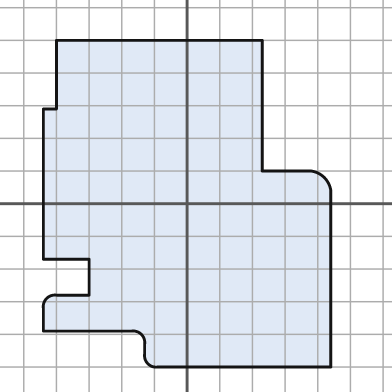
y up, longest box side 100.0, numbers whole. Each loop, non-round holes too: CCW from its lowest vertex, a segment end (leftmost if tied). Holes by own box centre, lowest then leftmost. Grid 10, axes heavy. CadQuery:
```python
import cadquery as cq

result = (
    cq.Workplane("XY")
    .moveTo(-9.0, -50.0)
    .lineTo(44.0, -50.0)
    .lineTo(44.0, 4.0)
    .threePointArc((42.0, 8.0), (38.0, 10.0))
    .lineTo(23.0, 10.0)
    .lineTo(23.0, 50.0)
    .lineTo(-40.0, 50.0)
    .lineTo(-40.0, 29.0)
    .lineTo(-44.0, 29.0)
    .lineTo(-44.0, -17.0)
    .lineTo(-30.0, -17.0)
    .lineTo(-30.0, -28.0)
    .lineTo(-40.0, -28.0)
    .threePointArc((-43.0, -29.0), (-44.0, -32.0))
    .lineTo(-44.0, -39.0)
    .lineTo(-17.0, -39.0)
    .threePointArc((-14.0, -40.0), (-13.0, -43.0))
    .lineTo(-13.0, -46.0)
    .threePointArc((-12.0, -49.0), (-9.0, -50.0))
    .close()
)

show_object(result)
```